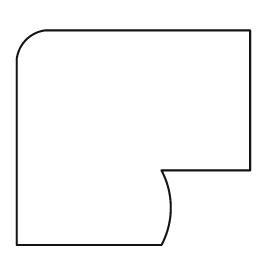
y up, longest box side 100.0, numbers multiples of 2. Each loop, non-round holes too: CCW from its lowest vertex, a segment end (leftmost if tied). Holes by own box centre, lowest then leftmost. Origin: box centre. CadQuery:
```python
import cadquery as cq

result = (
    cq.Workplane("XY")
    .moveTo(-50.0, -46.0)
    .lineTo(12.0, -46.0)
    .threePointArc((16.0, -30.0), (12.0, -14.0))
    .lineTo(50.0, -14.0)
    .lineTo(50.0, 46.0)
    .lineTo(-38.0, 46.0)
    .threePointArc((-46.0, 42.0), (-50.0, 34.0))
    .close()
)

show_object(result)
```